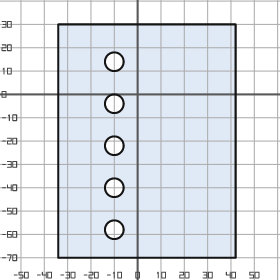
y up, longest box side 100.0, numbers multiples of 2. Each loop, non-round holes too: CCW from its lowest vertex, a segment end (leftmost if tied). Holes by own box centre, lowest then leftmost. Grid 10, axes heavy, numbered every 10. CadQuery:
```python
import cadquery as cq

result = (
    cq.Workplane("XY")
    .moveTo(-34.0, -70.0)
    .lineTo(42.0, -70.0)
    .lineTo(42.0, 30.0)
    .lineTo(-34.0, 30.0)
    .close()
    .moveTo(-10.0, -58.0)
    .circle(4.0)
    .moveTo(-10.0, -40.0)
    .circle(4.0)
    .moveTo(-10.0, -22.0)
    .circle(4.0)
    .moveTo(-10.0, -4.0)
    .circle(4.0)
    .moveTo(-10.0, 14.0)
    .circle(4.0)
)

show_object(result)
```